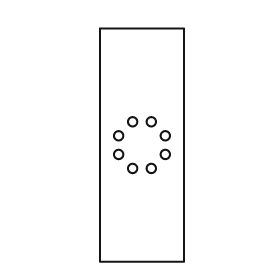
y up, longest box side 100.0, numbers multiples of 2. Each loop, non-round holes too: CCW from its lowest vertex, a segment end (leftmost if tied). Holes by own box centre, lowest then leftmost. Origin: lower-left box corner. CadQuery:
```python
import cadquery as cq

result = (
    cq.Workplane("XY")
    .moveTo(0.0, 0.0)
    .lineTo(36.0, 0.0)
    .lineTo(36.0, 100.0)
    .lineTo(0.0, 100.0)
    .close()
    .moveTo(14.0, 40.0)
    .circle(2.0)
    .moveTo(22.0, 40.0)
    .circle(2.0)
    .moveTo(8.0, 46.0)
    .circle(2.0)
    .moveTo(28.0, 46.0)
    .circle(2.0)
    .moveTo(8.0, 54.0)
    .circle(2.0)
    .moveTo(28.0, 54.0)
    .circle(2.0)
    .moveTo(14.0, 60.0)
    .circle(2.0)
    .moveTo(22.0, 60.0)
    .circle(2.0)
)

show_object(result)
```